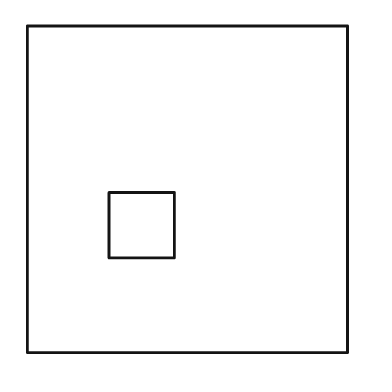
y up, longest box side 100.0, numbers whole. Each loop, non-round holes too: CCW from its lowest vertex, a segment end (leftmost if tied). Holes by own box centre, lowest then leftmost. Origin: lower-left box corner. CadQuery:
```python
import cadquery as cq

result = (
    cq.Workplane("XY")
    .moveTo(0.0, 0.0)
    .lineTo(98.0, 0.0)
    .lineTo(98.0, 100.0)
    .lineTo(0.0, 100.0)
    .close()
    .moveTo(25.0, 29.0)
    .lineTo(45.0, 29.0)
    .lineTo(45.0, 49.0)
    .lineTo(25.0, 49.0)
    .close()
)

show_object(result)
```